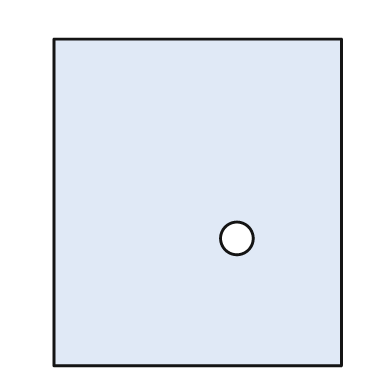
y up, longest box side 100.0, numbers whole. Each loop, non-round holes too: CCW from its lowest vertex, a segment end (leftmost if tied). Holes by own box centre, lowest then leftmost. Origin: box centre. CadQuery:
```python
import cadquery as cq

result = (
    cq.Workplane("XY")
    .moveTo(-44.0, -50.0)
    .lineTo(44.0, -50.0)
    .lineTo(44.0, 50.0)
    .lineTo(-44.0, 50.0)
    .close()
    .moveTo(12.0, -11.0)
    .circle(5.0)
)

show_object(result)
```